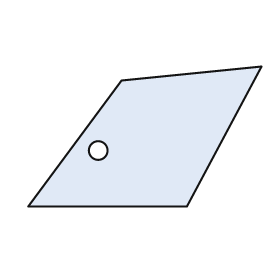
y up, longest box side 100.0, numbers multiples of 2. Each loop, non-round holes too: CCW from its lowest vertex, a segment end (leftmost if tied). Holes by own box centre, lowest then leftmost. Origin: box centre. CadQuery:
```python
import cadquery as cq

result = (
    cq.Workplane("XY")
    .moveTo(-50.0, -30.0)
    .lineTo(18.0, -30.0)
    .lineTo(50.0, 30.0)
    .lineTo(-10.0, 24.0)
    .close()
    .moveTo(-20.0, -6.0)
    .circle(4.0)
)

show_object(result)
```